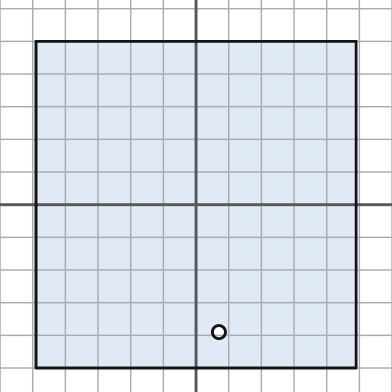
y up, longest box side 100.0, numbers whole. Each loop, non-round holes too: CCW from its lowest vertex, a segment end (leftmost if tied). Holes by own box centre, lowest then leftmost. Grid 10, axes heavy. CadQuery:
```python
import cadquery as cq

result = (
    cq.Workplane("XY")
    .moveTo(-49.0, -50.0)
    .lineTo(49.0, -50.0)
    .lineTo(49.0, 50.0)
    .lineTo(-49.0, 50.0)
    .close()
    .moveTo(7.0, -39.0)
    .circle(2.0)
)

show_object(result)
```